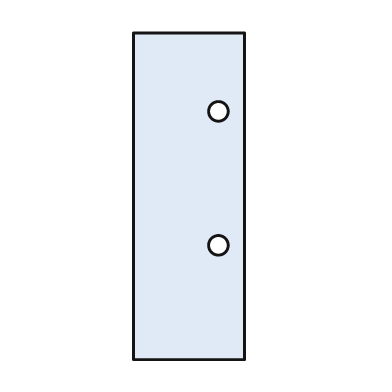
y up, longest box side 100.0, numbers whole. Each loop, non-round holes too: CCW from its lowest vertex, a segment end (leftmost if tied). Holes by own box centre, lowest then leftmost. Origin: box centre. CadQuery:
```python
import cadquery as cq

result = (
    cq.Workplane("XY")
    .moveTo(-17.0, -50.0)
    .lineTo(17.0, -50.0)
    .lineTo(17.0, 50.0)
    .lineTo(-17.0, 50.0)
    .close()
    .moveTo(9.0, -15.0)
    .circle(3.0)
    .moveTo(9.0, 26.0)
    .circle(3.0)
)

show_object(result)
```